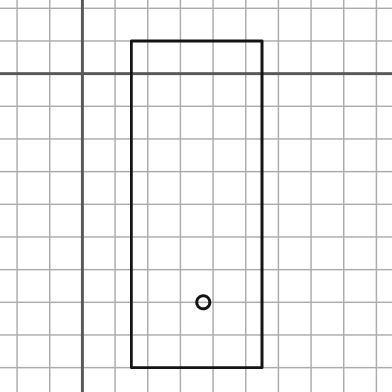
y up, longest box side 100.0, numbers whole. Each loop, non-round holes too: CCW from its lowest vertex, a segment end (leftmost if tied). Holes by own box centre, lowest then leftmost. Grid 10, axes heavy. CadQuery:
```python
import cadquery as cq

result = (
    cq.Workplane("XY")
    .moveTo(15.0, -90.0)
    .lineTo(55.0, -90.0)
    .lineTo(55.0, 10.0)
    .lineTo(15.0, 10.0)
    .close()
    .moveTo(37.0, -70.0)
    .circle(2.0)
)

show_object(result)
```